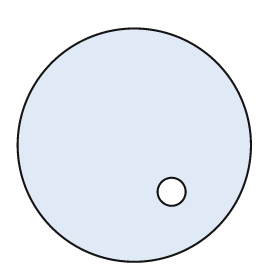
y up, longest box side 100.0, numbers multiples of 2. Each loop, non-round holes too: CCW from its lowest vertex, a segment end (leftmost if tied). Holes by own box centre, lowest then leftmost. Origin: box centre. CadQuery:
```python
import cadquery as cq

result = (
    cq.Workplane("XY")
    .moveTo(0.0, 0.0)
    .circle(50.0)
    .moveTo(16.0, -20.0)
    .circle(6.0)
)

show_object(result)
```